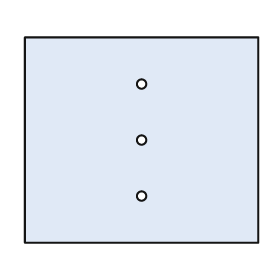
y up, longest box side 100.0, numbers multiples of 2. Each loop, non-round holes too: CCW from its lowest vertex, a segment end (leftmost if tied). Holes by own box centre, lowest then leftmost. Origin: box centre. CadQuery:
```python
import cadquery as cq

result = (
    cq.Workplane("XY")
    .moveTo(-50.0, -44.0)
    .lineTo(50.0, -44.0)
    .lineTo(50.0, 44.0)
    .lineTo(-50.0, 44.0)
    .close()
    .moveTo(0.0, -24.0)
    .circle(2.0)
    .moveTo(0.0, 0.0)
    .circle(2.0)
    .moveTo(0.0, 24.0)
    .circle(2.0)
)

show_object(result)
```